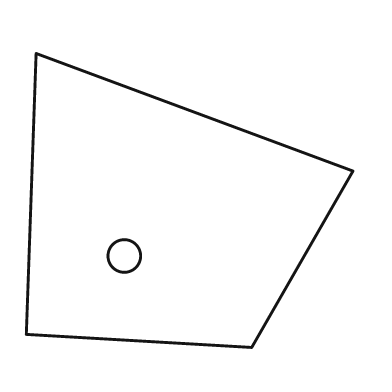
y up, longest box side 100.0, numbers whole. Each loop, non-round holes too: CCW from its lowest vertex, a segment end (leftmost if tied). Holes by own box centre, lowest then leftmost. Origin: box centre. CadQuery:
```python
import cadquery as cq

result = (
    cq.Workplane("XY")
    .moveTo(19.0, -45.0)
    .lineTo(50.0, 9.0)
    .lineTo(-47.0, 45.0)
    .lineTo(-50.0, -41.0)
    .close()
    .moveTo(-20.0, -17.0)
    .circle(5.0)
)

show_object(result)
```